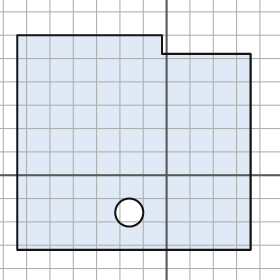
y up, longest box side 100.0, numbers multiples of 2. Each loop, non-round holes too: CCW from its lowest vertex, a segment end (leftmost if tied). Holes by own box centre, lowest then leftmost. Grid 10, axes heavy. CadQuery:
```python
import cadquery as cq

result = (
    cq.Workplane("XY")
    .moveTo(-64.0, -32.0)
    .lineTo(36.0, -32.0)
    .lineTo(36.0, 52.0)
    .lineTo(-2.0, 52.0)
    .lineTo(-2.0, 60.0)
    .lineTo(-64.0, 60.0)
    .close()
    .moveTo(-16.0, -16.0)
    .circle(6.0)
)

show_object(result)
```